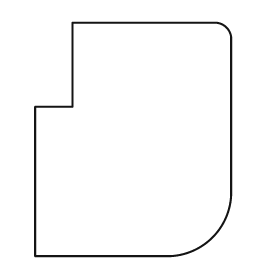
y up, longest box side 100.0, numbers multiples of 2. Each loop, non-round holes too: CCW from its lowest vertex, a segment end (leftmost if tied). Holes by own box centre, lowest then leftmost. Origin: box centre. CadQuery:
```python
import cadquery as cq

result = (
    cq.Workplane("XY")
    .moveTo(-42.0, -50.0)
    .lineTo(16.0, -50.0)
    .threePointArc((34.0, -42.0), (42.0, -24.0))
    .lineTo(42.0, 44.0)
    .threePointArc((40.0, 48.0), (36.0, 50.0))
    .lineTo(-26.0, 50.0)
    .lineTo(-26.0, 14.0)
    .lineTo(-42.0, 14.0)
    .close()
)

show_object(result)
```